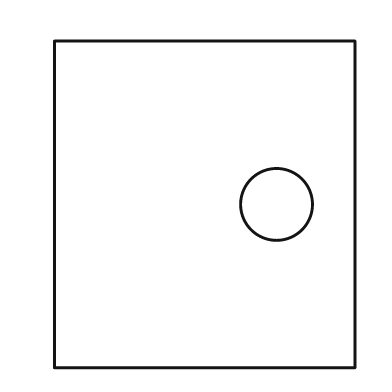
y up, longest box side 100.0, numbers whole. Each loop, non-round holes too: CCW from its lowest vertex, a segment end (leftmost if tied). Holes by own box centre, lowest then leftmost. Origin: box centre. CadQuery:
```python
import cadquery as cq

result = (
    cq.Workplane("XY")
    .moveTo(-46.0, -50.0)
    .lineTo(46.0, -50.0)
    .lineTo(46.0, 50.0)
    .lineTo(-46.0, 50.0)
    .close()
    .moveTo(22.0, 0.0)
    .circle(11.0)
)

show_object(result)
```